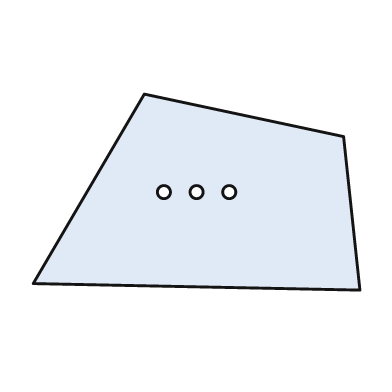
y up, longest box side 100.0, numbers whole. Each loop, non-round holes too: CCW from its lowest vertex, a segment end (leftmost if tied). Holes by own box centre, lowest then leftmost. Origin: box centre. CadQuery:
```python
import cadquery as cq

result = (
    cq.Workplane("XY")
    .moveTo(50.0, -30.0)
    .lineTo(45.0, 17.0)
    .lineTo(-16.0, 30.0)
    .lineTo(-50.0, -28.0)
    .close()
    .moveTo(-10.0, 0.0)
    .circle(2.0)
    .moveTo(0.0, 0.0)
    .circle(2.0)
    .moveTo(10.0, 0.0)
    .circle(2.0)
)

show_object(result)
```